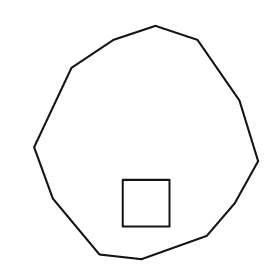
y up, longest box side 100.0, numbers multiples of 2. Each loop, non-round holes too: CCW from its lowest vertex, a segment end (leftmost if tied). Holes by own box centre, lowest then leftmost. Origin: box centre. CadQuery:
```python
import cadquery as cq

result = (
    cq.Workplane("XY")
    .moveTo(-2.0, -50.0)
    .lineTo(26.0, -40.0)
    .lineTo(38.0, -26.0)
    .lineTo(48.0, -8.0)
    .lineTo(40.0, 18.0)
    .lineTo(22.0, 44.0)
    .lineTo(4.0, 50.0)
    .lineTo(-14.0, 44.0)
    .lineTo(-32.0, 32.0)
    .lineTo(-48.0, -2.0)
    .lineTo(-40.0, -24.0)
    .lineTo(-20.0, -48.0)
    .close()
    .moveTo(-10.0, -36.0)
    .lineTo(10.0, -36.0)
    .lineTo(10.0, -16.0)
    .lineTo(-10.0, -16.0)
    .close()
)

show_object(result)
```